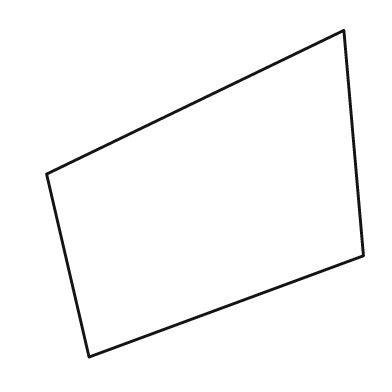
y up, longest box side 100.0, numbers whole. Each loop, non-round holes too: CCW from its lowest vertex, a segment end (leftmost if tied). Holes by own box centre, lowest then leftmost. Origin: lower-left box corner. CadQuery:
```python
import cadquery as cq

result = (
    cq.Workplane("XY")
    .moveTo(13.0, 0.0)
    .lineTo(97.0, 31.0)
    .lineTo(91.0, 100.0)
    .lineTo(0.0, 56.0)
    .close()
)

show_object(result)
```